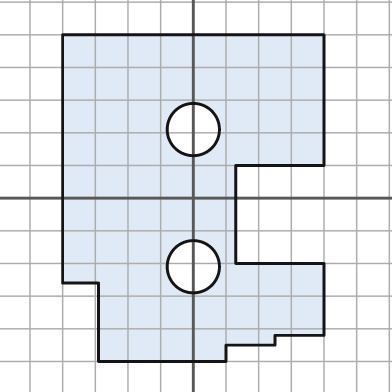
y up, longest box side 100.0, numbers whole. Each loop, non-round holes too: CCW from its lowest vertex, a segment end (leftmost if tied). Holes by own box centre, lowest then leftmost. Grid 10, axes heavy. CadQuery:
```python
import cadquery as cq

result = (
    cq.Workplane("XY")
    .moveTo(-29.0, -50.0)
    .lineTo(10.0, -50.0)
    .lineTo(10.0, -45.0)
    .lineTo(25.0, -45.0)
    .lineTo(25.0, -42.0)
    .lineTo(40.0, -42.0)
    .lineTo(40.0, -20.0)
    .lineTo(13.0, -20.0)
    .lineTo(13.0, 10.0)
    .lineTo(40.0, 10.0)
    .lineTo(40.0, 50.0)
    .lineTo(-40.0, 50.0)
    .lineTo(-40.0, -26.0)
    .lineTo(-29.0, -26.0)
    .close()
    .moveTo(0.0, -21.0)
    .circle(8.0)
    .moveTo(0.0, 21.0)
    .circle(8.0)
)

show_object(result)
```